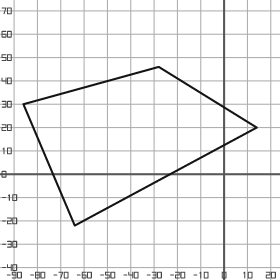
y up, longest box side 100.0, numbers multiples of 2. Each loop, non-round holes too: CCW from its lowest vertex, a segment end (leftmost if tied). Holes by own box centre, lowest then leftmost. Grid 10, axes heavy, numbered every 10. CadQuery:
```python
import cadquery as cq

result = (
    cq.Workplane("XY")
    .moveTo(-64.0, -22.0)
    .lineTo(14.0, 20.0)
    .lineTo(-28.0, 46.0)
    .lineTo(-86.0, 30.0)
    .close()
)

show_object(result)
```